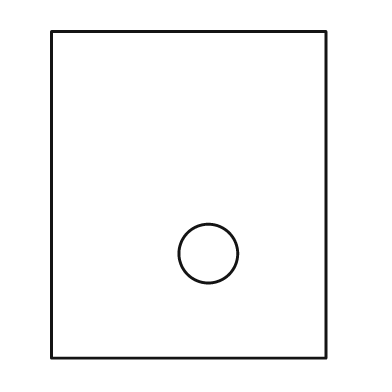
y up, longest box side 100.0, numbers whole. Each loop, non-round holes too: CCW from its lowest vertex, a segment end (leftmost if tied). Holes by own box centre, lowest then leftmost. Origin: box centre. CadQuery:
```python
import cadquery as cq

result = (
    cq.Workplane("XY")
    .moveTo(-42.0, -50.0)
    .lineTo(42.0, -50.0)
    .lineTo(42.0, 50.0)
    .lineTo(-42.0, 50.0)
    .close()
    .moveTo(6.0, -18.0)
    .circle(9.0)
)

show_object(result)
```